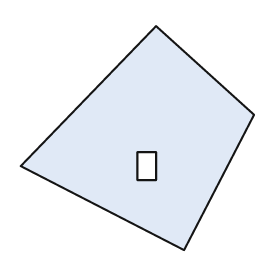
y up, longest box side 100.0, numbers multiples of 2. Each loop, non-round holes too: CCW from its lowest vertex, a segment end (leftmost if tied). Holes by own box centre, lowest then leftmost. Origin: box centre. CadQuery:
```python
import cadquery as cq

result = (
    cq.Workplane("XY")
    .moveTo(20.0, -48.0)
    .lineTo(50.0, 10.0)
    .lineTo(8.0, 48.0)
    .lineTo(-50.0, -12.0)
    .close()
    .moveTo(0.0, -18.0)
    .lineTo(8.0, -18.0)
    .lineTo(8.0, -6.0)
    .lineTo(0.0, -6.0)
    .close()
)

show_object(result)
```